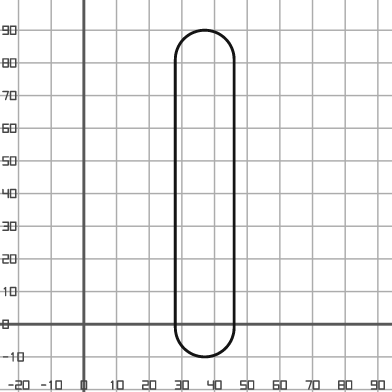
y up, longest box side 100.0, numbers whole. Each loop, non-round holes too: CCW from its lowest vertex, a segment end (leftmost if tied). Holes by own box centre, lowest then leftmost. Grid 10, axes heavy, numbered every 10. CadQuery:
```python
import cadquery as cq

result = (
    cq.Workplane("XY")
    .moveTo(28.0, -1.0)
    .threePointArc((37.0, -10.0), (46.0, -1.0))
    .lineTo(46.0, 81.0)
    .threePointArc((37.0, 90.0), (28.0, 81.0))
    .close()
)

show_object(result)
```